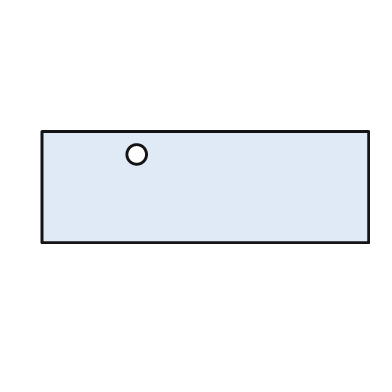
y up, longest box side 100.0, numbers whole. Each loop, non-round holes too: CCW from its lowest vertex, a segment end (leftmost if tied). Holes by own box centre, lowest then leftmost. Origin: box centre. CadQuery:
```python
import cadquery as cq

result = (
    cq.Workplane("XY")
    .moveTo(-50.0, -17.0)
    .lineTo(50.0, -17.0)
    .lineTo(50.0, 17.0)
    .lineTo(-50.0, 17.0)
    .close()
    .moveTo(-21.0, 10.0)
    .circle(3.0)
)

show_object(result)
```